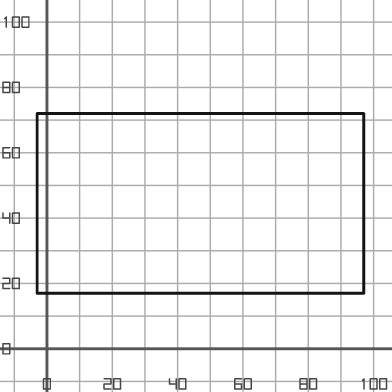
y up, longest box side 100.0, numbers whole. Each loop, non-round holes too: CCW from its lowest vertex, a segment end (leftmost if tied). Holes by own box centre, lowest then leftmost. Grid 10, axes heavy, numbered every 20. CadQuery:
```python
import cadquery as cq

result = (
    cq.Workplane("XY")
    .moveTo(-3.0, 17.0)
    .lineTo(97.0, 17.0)
    .lineTo(97.0, 72.0)
    .lineTo(-3.0, 72.0)
    .close()
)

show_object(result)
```